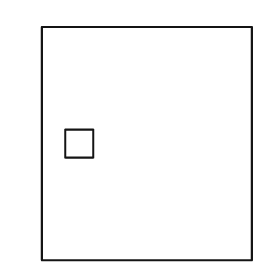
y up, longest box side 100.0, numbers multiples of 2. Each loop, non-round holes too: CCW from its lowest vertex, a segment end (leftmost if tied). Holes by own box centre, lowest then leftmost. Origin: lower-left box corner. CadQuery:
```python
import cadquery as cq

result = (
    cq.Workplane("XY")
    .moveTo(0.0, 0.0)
    .lineTo(90.0, 0.0)
    .lineTo(90.0, 100.0)
    .lineTo(0.0, 100.0)
    .close()
    .moveTo(10.0, 44.0)
    .lineTo(22.0, 44.0)
    .lineTo(22.0, 56.0)
    .lineTo(10.0, 56.0)
    .close()
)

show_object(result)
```